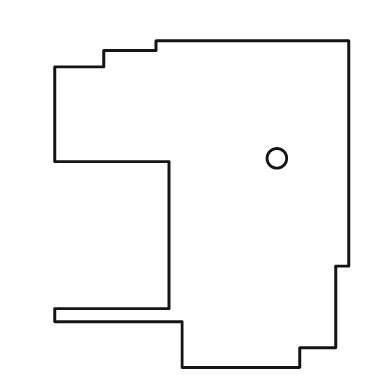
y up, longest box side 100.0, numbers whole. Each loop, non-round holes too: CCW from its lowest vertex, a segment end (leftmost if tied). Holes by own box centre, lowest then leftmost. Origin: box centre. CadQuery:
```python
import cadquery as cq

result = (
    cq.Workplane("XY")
    .moveTo(-6.0, -50.0)
    .lineTo(30.0, -50.0)
    .lineTo(30.0, -44.0)
    .lineTo(41.0, -44.0)
    .lineTo(41.0, -19.0)
    .lineTo(45.0, -19.0)
    .lineTo(45.0, 50.0)
    .lineTo(-14.0, 50.0)
    .lineTo(-14.0, 47.0)
    .lineTo(-30.0, 47.0)
    .lineTo(-30.0, 42.0)
    .lineTo(-45.0, 42.0)
    .lineTo(-45.0, 13.0)
    .lineTo(-10.0, 13.0)
    .lineTo(-10.0, -32.0)
    .lineTo(-45.0, -32.0)
    .lineTo(-45.0, -36.0)
    .lineTo(-6.0, -36.0)
    .close()
    .moveTo(23.0, 14.0)
    .circle(3.0)
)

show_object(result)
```